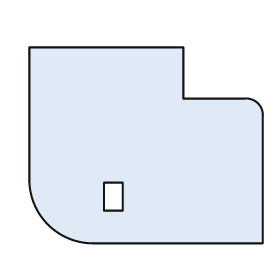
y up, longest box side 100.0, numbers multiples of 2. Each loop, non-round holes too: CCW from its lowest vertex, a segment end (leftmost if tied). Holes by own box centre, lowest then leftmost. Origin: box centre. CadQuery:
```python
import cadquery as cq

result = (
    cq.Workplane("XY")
    .moveTo(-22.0, -42.0)
    .lineTo(50.0, -42.0)
    .lineTo(50.0, 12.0)
    .threePointArc((48.0, 18.0), (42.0, 20.0))
    .lineTo(16.0, 20.0)
    .lineTo(16.0, 42.0)
    .lineTo(-50.0, 42.0)
    .lineTo(-50.0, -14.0)
    .threePointArc((-42.0, -34.0), (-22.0, -42.0))
    .close()
    .moveTo(-18.0, -28.0)
    .lineTo(-10.0, -28.0)
    .lineTo(-10.0, -16.0)
    .lineTo(-18.0, -16.0)
    .close()
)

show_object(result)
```